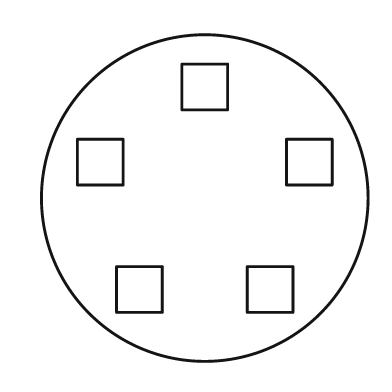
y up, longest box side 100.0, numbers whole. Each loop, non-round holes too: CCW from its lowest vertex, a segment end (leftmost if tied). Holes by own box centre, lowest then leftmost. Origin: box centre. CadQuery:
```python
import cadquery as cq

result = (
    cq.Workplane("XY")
    .moveTo(0.0, 0.0)
    .circle(50.0)
    .moveTo(-27.0, -35.0)
    .lineTo(-13.0, -35.0)
    .lineTo(-13.0, -21.0)
    .lineTo(-27.0, -21.0)
    .close()
    .moveTo(13.0, -35.0)
    .lineTo(27.0, -35.0)
    .lineTo(27.0, -21.0)
    .lineTo(13.0, -21.0)
    .close()
    .moveTo(-39.0, 4.0)
    .lineTo(-25.0, 4.0)
    .lineTo(-25.0, 18.0)
    .lineTo(-39.0, 18.0)
    .close()
    .moveTo(25.0, 4.0)
    .lineTo(39.0, 4.0)
    .lineTo(39.0, 18.0)
    .lineTo(25.0, 18.0)
    .close()
    .moveTo(-7.0, 27.0)
    .lineTo(7.0, 27.0)
    .lineTo(7.0, 41.0)
    .lineTo(-7.0, 41.0)
    .close()
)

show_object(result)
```